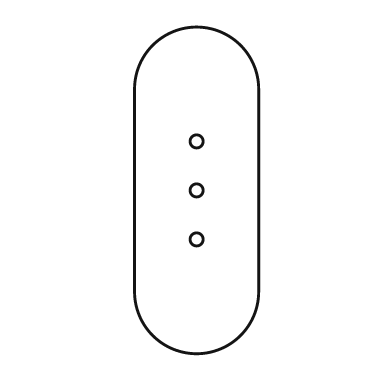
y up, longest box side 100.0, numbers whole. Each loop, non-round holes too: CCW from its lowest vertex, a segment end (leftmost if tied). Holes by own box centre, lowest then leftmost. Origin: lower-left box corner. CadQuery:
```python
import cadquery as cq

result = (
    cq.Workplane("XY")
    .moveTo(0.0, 19.0)
    .threePointArc((19.0, 0.0), (38.0, 19.0))
    .lineTo(38.0, 81.0)
    .threePointArc((19.0, 100.0), (0.0, 81.0))
    .close()
    .moveTo(19.0, 35.0)
    .circle(2.0)
    .moveTo(19.0, 50.0)
    .circle(2.0)
    .moveTo(19.0, 65.0)
    .circle(2.0)
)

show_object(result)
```